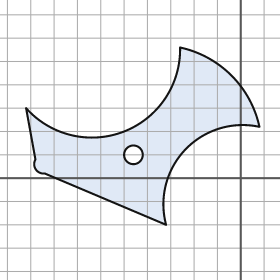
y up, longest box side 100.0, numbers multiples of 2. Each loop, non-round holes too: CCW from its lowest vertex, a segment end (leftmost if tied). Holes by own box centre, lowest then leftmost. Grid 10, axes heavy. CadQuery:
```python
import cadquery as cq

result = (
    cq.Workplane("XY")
    .moveTo(-32.0, -20.0)
    .threePointArc((-24.0, 12.0), (8.0, 22.0))
    .threePointArc((-4.0, 44.0), (-26.0, 56.0))
    .threePointArc((-50.0, 20.0), (-92.0, 30.0))
    .lineTo(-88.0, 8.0)
    .threePointArc((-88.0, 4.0), (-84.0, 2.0))
    .close()
    .moveTo(-46.0, 10.0)
    .circle(4.0)
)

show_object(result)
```